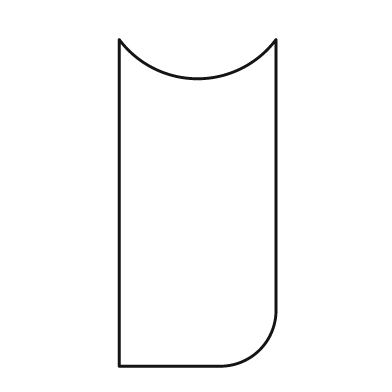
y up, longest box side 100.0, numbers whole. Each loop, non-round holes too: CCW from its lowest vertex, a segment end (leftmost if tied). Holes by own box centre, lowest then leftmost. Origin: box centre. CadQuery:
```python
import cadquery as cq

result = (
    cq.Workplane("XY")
    .moveTo(-24.0, -50.0)
    .lineTo(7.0, -50.0)
    .threePointArc((19.0, -45.0), (24.0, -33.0))
    .lineTo(24.0, 50.0)
    .threePointArc((0.0, 38.0), (-24.0, 50.0))
    .close()
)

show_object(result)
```